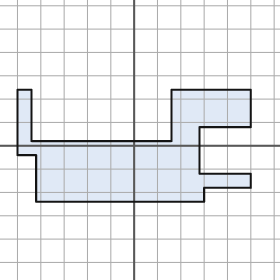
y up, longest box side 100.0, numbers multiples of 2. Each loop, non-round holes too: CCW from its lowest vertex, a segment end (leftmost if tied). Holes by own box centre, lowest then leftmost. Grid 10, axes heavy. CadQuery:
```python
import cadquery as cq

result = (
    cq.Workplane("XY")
    .moveTo(-42.0, -24.0)
    .lineTo(30.0, -24.0)
    .lineTo(30.0, -18.0)
    .lineTo(50.0, -18.0)
    .lineTo(50.0, -12.0)
    .lineTo(28.0, -12.0)
    .lineTo(28.0, 8.0)
    .lineTo(50.0, 8.0)
    .lineTo(50.0, 24.0)
    .lineTo(16.0, 24.0)
    .lineTo(16.0, 2.0)
    .lineTo(-44.0, 2.0)
    .lineTo(-44.0, 24.0)
    .lineTo(-50.0, 24.0)
    .lineTo(-50.0, -4.0)
    .lineTo(-42.0, -4.0)
    .close()
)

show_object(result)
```